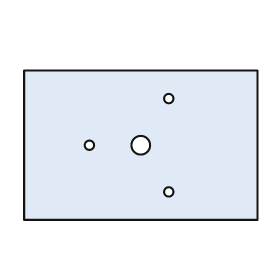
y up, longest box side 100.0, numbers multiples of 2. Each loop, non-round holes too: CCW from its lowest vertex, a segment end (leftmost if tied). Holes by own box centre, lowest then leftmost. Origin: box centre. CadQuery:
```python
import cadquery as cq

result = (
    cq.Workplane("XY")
    .moveTo(-50.0, -32.0)
    .lineTo(50.0, -32.0)
    .lineTo(50.0, 32.0)
    .lineTo(-50.0, 32.0)
    .close()
    .moveTo(12.0, -20.0)
    .circle(2.0)
    .moveTo(-22.0, 0.0)
    .circle(2.0)
    .moveTo(0.0, 0.0)
    .circle(4.0)
    .moveTo(12.0, 20.0)
    .circle(2.0)
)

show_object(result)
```